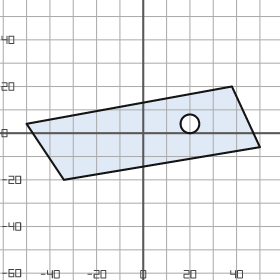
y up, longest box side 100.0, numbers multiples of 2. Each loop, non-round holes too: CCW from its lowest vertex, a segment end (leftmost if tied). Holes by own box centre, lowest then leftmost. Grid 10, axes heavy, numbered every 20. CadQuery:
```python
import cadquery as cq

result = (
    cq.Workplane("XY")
    .moveTo(-34.0, -20.0)
    .lineTo(50.0, -6.0)
    .lineTo(38.0, 20.0)
    .lineTo(-50.0, 4.0)
    .close()
    .moveTo(20.0, 4.0)
    .circle(4.0)
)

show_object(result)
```